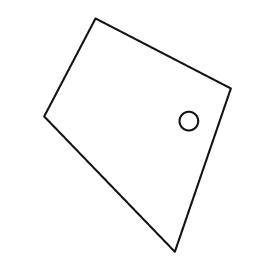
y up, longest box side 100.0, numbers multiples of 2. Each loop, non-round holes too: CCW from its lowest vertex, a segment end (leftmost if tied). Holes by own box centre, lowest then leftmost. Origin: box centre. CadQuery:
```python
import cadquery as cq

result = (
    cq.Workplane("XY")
    .moveTo(16.0, -50.0)
    .lineTo(40.0, 20.0)
    .lineTo(-18.0, 50.0)
    .lineTo(-40.0, 8.0)
    .close()
    .moveTo(22.0, 6.0)
    .circle(4.0)
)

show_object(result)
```